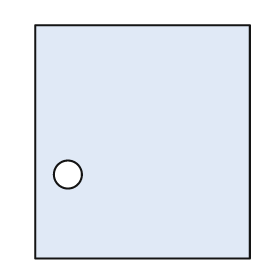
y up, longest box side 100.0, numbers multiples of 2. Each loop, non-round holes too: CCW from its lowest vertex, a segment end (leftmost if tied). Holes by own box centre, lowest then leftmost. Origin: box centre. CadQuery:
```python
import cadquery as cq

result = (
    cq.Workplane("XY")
    .moveTo(-46.0, -50.0)
    .lineTo(46.0, -50.0)
    .lineTo(46.0, 50.0)
    .lineTo(-46.0, 50.0)
    .close()
    .moveTo(-32.0, -14.0)
    .circle(6.0)
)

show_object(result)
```